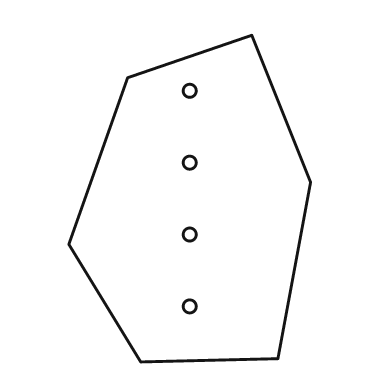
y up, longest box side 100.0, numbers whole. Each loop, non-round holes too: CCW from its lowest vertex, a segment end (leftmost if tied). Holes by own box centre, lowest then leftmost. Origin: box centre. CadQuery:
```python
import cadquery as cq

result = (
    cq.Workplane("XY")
    .moveTo(-15.0, -50.0)
    .lineTo(27.0, -49.0)
    .lineTo(37.0, 5.0)
    .lineTo(19.0, 50.0)
    .lineTo(-19.0, 37.0)
    .lineTo(-37.0, -14.0)
    .close()
    .moveTo(0.0, -33.0)
    .circle(2.0)
    .moveTo(0.0, -11.0)
    .circle(2.0)
    .moveTo(0.0, 11.0)
    .circle(2.0)
    .moveTo(0.0, 33.0)
    .circle(2.0)
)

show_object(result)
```